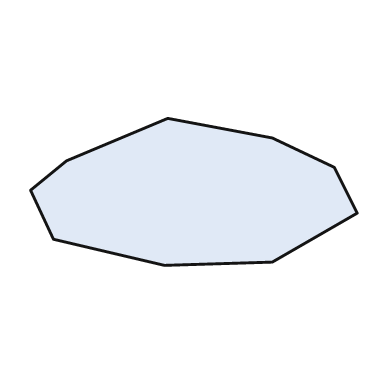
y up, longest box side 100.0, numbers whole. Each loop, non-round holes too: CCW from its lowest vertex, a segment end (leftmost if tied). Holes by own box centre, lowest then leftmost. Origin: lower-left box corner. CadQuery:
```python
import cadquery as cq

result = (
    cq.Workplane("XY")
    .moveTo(41.0, 0.0)
    .lineTo(74.0, 1.0)
    .lineTo(100.0, 16.0)
    .lineTo(93.0, 30.0)
    .lineTo(74.0, 39.0)
    .lineTo(42.0, 45.0)
    .lineTo(11.0, 32.0)
    .lineTo(0.0, 23.0)
    .lineTo(7.0, 8.0)
    .close()
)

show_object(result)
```